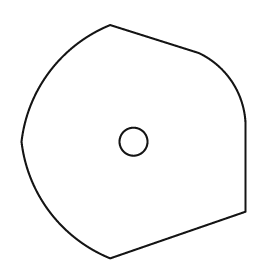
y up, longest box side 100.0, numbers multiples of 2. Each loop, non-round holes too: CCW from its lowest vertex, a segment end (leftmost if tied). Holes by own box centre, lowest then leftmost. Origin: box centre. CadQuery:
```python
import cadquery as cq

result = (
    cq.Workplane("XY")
    .moveTo(-10.0, -50.0)
    .lineTo(48.0, -30.0)
    .lineTo(48.0, 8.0)
    .threePointArc((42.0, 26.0), (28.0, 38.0))
    .lineTo(-10.0, 50.0)
    .threePointArc((-36.0, 30.0), (-48.0, 0.0))
    .threePointArc((-36.0, -30.0), (-10.0, -50.0))
    .close()
    .moveTo(0.0, 0.0)
    .circle(6.0)
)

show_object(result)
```